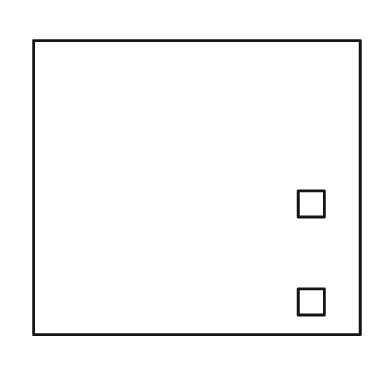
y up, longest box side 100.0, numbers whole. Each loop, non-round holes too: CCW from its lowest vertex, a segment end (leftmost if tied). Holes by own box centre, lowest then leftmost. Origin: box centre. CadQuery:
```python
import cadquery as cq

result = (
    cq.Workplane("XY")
    .moveTo(-50.0, -45.0)
    .lineTo(50.0, -45.0)
    .lineTo(50.0, 45.0)
    .lineTo(-50.0, 45.0)
    .close()
    .moveTo(31.0, -39.0)
    .lineTo(39.0, -39.0)
    .lineTo(39.0, -31.0)
    .lineTo(31.0, -31.0)
    .close()
    .moveTo(31.0, -9.0)
    .lineTo(39.0, -9.0)
    .lineTo(39.0, -1.0)
    .lineTo(31.0, -1.0)
    .close()
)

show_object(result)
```